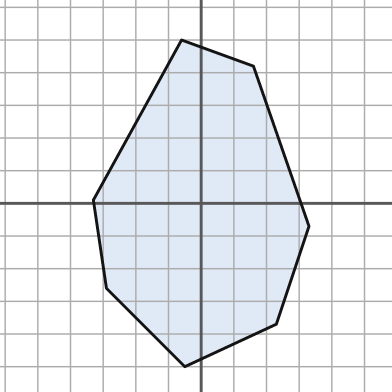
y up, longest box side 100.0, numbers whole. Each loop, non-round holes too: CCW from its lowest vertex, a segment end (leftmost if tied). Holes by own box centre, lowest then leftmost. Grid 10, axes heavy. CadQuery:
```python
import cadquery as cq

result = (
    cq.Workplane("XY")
    .moveTo(-5.0, -50.0)
    .lineTo(23.0, -37.0)
    .lineTo(33.0, -7.0)
    .lineTo(16.0, 42.0)
    .lineTo(-6.0, 50.0)
    .lineTo(-33.0, 1.0)
    .lineTo(-29.0, -26.0)
    .close()
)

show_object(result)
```